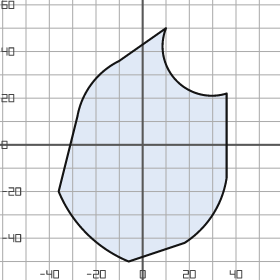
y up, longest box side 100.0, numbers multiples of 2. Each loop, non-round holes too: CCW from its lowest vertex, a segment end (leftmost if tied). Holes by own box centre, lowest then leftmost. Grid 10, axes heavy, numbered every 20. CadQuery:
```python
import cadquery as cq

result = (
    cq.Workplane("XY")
    .moveTo(-6.0, -50.0)
    .lineTo(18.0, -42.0)
    .threePointArc((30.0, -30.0), (36.0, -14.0))
    .lineTo(36.0, 22.0)
    .threePointArc((14.0, 28.0), (10.0, 50.0))
    .lineTo(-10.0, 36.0)
    .threePointArc((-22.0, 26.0), (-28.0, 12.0))
    .lineTo(-36.0, -20.0)
    .threePointArc((-24.0, -38.0), (-6.0, -50.0))
    .close()
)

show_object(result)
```